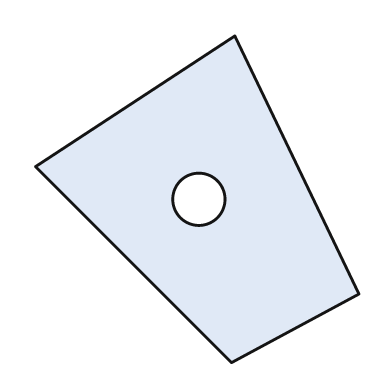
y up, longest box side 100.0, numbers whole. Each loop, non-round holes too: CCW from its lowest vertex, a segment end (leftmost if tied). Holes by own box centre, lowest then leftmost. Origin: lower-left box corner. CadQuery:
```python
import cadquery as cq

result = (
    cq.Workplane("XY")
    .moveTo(60.0, 0.0)
    .lineTo(99.0, 21.0)
    .lineTo(61.0, 100.0)
    .lineTo(0.0, 60.0)
    .close()
    .moveTo(50.0, 50.0)
    .circle(8.0)
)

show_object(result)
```